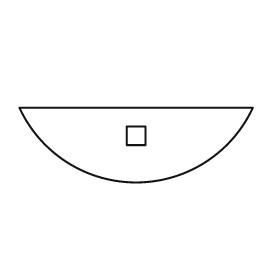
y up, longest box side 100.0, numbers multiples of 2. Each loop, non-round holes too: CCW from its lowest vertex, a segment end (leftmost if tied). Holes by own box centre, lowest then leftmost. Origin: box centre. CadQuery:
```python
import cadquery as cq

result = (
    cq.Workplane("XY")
    .moveTo(-50.0, 16.0)
    .threePointArc((0.0, -16.0), (50.0, 16.0))
    .close()
    .moveTo(-4.0, 0.0)
    .lineTo(4.0, 0.0)
    .lineTo(4.0, 8.0)
    .lineTo(-4.0, 8.0)
    .close()
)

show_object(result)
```